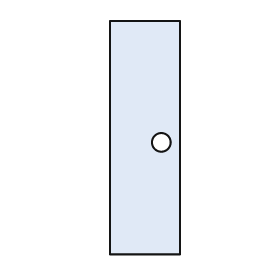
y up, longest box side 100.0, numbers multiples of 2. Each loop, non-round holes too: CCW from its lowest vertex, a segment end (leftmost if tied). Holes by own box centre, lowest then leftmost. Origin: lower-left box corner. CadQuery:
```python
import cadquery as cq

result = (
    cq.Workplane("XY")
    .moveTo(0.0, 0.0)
    .lineTo(30.0, 0.0)
    .lineTo(30.0, 100.0)
    .lineTo(0.0, 100.0)
    .close()
    .moveTo(22.0, 48.0)
    .circle(4.0)
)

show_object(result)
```